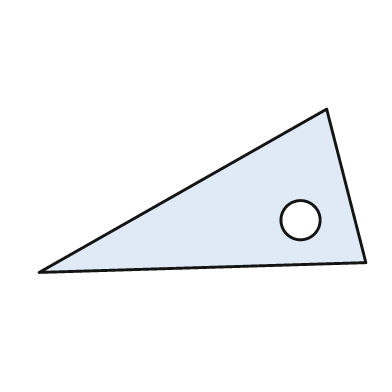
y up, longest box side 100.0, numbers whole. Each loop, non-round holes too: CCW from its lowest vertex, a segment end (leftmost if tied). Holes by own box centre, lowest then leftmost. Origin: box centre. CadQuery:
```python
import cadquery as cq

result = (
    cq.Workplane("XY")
    .moveTo(-50.0, -25.0)
    .lineTo(50.0, -22.0)
    .lineTo(38.0, 25.0)
    .close()
    .moveTo(30.0, -9.0)
    .circle(6.0)
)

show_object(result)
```